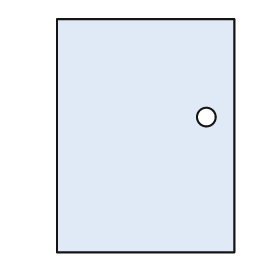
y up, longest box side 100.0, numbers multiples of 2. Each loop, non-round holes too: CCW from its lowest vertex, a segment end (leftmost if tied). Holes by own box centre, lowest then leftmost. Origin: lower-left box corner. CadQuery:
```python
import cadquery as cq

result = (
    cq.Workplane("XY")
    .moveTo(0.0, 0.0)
    .lineTo(76.0, 0.0)
    .lineTo(76.0, 100.0)
    .lineTo(0.0, 100.0)
    .close()
    .moveTo(64.0, 58.0)
    .circle(4.0)
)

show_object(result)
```